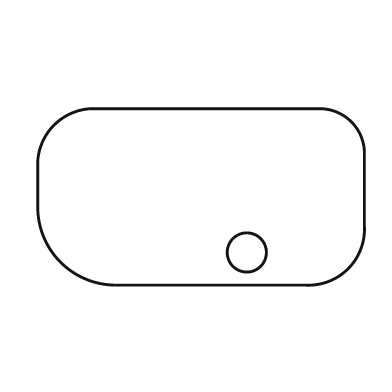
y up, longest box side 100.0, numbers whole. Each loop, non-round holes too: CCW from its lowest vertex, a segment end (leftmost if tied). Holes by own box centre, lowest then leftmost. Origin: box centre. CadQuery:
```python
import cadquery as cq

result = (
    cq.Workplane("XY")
    .moveTo(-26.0, -27.0)
    .lineTo(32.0, -27.0)
    .threePointArc((45.0, -22.0), (50.0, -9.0))
    .lineTo(50.0, 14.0)
    .threePointArc((46.0, 23.0), (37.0, 27.0))
    .lineTo(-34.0, 27.0)
    .threePointArc((-45.0, 22.0), (-50.0, 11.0))
    .lineTo(-50.0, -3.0)
    .threePointArc((-43.0, -20.0), (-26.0, -27.0))
    .close()
    .moveTo(14.0, -17.0)
    .circle(6.0)
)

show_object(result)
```